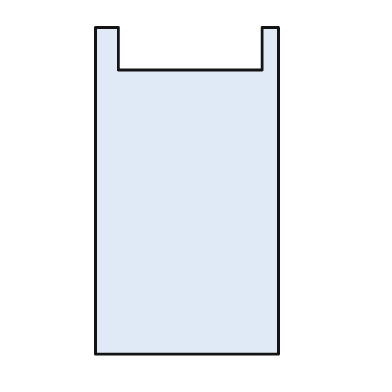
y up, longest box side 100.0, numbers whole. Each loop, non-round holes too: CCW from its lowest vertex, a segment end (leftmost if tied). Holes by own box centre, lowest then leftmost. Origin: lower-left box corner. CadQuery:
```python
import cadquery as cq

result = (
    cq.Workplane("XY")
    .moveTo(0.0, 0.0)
    .lineTo(56.0, 0.0)
    .lineTo(56.0, 100.0)
    .lineTo(51.0, 100.0)
    .lineTo(51.0, 87.0)
    .lineTo(7.0, 87.0)
    .lineTo(7.0, 100.0)
    .lineTo(0.0, 100.0)
    .close()
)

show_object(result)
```